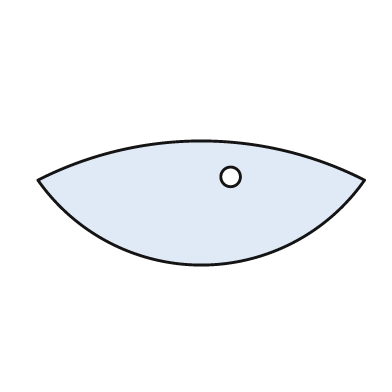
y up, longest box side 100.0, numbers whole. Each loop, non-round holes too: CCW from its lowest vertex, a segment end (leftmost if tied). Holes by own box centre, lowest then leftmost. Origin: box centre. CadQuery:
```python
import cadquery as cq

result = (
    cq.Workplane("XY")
    .moveTo(-50.0, 7.0)
    .threePointArc((0.0, -19.0), (50.0, 7.0))
    .threePointArc((0.0, 19.0), (-50.0, 7.0))
    .close()
    .moveTo(9.0, 8.0)
    .circle(3.0)
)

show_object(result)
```